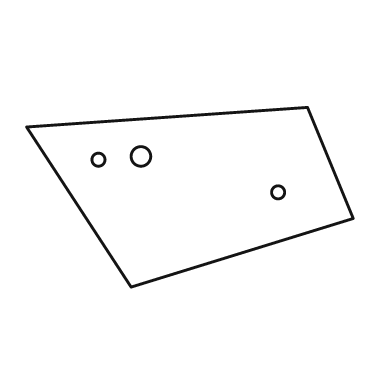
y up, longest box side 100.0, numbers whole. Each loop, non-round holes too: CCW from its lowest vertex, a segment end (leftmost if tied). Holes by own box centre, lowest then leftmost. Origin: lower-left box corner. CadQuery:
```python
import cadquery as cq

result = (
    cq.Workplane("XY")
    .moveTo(32.0, 0.0)
    .lineTo(100.0, 21.0)
    .lineTo(86.0, 55.0)
    .lineTo(0.0, 49.0)
    .close()
    .moveTo(77.0, 29.0)
    .circle(2.0)
    .moveTo(22.0, 39.0)
    .circle(2.0)
    .moveTo(35.0, 40.0)
    .circle(3.0)
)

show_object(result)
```